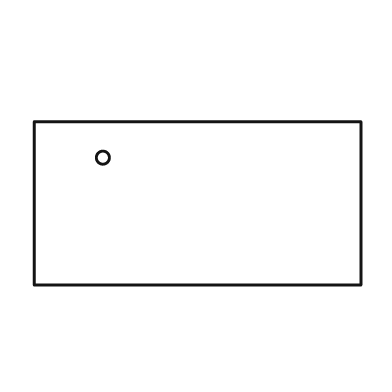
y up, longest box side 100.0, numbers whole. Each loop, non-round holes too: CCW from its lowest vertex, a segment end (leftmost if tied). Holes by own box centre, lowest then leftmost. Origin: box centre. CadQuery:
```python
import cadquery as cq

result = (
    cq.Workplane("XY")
    .moveTo(-50.0, -25.0)
    .lineTo(50.0, -25.0)
    .lineTo(50.0, 25.0)
    .lineTo(-50.0, 25.0)
    .close()
    .moveTo(-29.0, 14.0)
    .circle(2.0)
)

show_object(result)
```